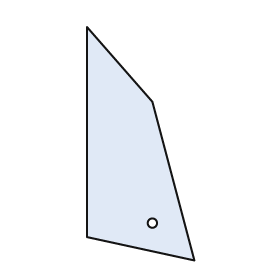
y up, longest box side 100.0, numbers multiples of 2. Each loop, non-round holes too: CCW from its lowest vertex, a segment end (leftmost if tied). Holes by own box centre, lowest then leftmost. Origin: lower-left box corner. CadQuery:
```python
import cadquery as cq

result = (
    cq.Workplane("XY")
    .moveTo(46.0, 0.0)
    .lineTo(28.0, 68.0)
    .lineTo(0.0, 100.0)
    .lineTo(0.0, 10.0)
    .close()
    .moveTo(28.0, 16.0)
    .circle(2.0)
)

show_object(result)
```